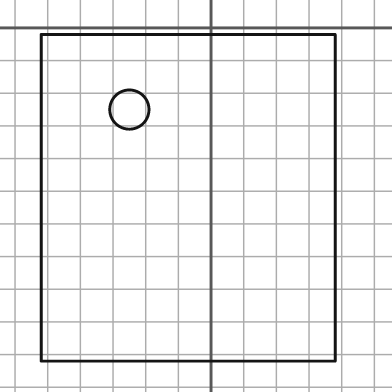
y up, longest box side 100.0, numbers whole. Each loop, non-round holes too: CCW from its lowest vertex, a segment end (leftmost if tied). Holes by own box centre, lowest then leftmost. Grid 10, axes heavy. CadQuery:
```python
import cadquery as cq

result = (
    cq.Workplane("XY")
    .moveTo(-52.0, -102.0)
    .lineTo(38.0, -102.0)
    .lineTo(38.0, -2.0)
    .lineTo(-52.0, -2.0)
    .close()
    .moveTo(-25.0, -25.0)
    .circle(6.0)
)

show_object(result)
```